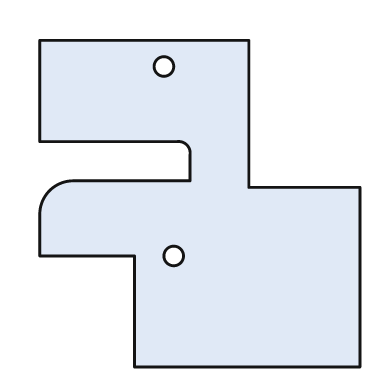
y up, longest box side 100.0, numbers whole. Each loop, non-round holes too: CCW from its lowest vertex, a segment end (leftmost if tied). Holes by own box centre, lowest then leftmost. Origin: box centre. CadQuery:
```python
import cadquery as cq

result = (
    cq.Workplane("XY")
    .moveTo(-20.0, -50.0)
    .lineTo(49.0, -50.0)
    .lineTo(49.0, 5.0)
    .lineTo(15.0, 5.0)
    .lineTo(15.0, 50.0)
    .lineTo(-49.0, 50.0)
    .lineTo(-49.0, 19.0)
    .lineTo(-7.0, 19.0)
    .threePointArc((-4.0, 18.0), (-3.0, 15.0))
    .lineTo(-3.0, 7.0)
    .lineTo(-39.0, 7.0)
    .threePointArc((-46.0, 4.0), (-49.0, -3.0))
    .lineTo(-49.0, -16.0)
    .lineTo(-20.0, -16.0)
    .close()
    .moveTo(-8.0, -16.0)
    .circle(3.0)
    .moveTo(-11.0, 42.0)
    .circle(3.0)
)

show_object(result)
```